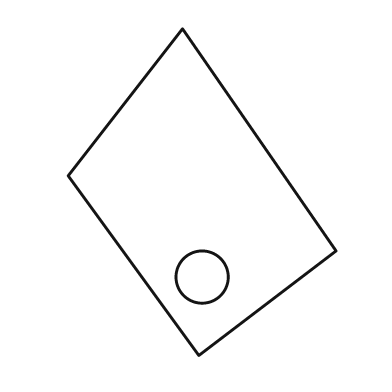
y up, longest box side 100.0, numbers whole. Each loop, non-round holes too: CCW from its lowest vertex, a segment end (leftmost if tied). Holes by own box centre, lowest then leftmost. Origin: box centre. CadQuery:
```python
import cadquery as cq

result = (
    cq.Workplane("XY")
    .moveTo(-1.0, -50.0)
    .lineTo(41.0, -18.0)
    .lineTo(-6.0, 50.0)
    .lineTo(-41.0, 5.0)
    .close()
    .moveTo(0.0, -26.0)
    .circle(8.0)
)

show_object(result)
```